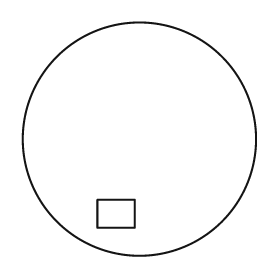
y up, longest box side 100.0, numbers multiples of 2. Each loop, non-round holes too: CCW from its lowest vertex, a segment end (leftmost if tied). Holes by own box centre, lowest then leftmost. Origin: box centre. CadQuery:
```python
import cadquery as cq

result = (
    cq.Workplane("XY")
    .moveTo(0.0, 0.0)
    .circle(50.0)
    .moveTo(-18.0, -38.0)
    .lineTo(-2.0, -38.0)
    .lineTo(-2.0, -26.0)
    .lineTo(-18.0, -26.0)
    .close()
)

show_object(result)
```